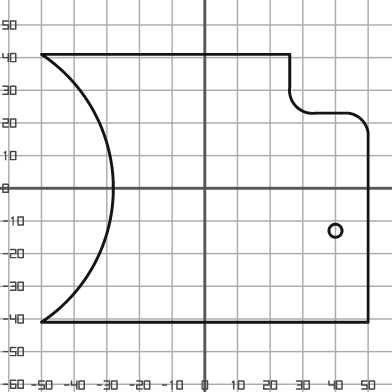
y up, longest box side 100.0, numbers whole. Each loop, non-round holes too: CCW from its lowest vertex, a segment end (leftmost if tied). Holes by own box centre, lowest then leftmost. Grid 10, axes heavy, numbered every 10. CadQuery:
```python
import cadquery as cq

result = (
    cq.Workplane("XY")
    .moveTo(-50.0, -41.0)
    .lineTo(50.0, -41.0)
    .lineTo(50.0, 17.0)
    .threePointArc((48.0, 21.0), (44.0, 23.0))
    .lineTo(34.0, 23.0)
    .threePointArc((28.0, 25.0), (26.0, 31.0))
    .lineTo(26.0, 41.0)
    .lineTo(-50.0, 41.0)
    .threePointArc((-28.0, 0.0), (-50.0, -41.0))
    .close()
    .moveTo(40.0, -13.0)
    .circle(2.0)
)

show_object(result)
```